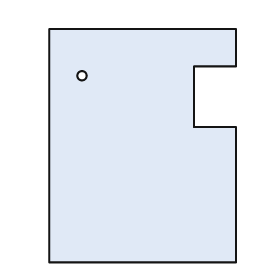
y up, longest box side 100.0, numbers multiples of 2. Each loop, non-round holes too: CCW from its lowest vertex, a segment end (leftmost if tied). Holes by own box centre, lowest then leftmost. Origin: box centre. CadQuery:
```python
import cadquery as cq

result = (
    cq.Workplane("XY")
    .moveTo(-40.0, -50.0)
    .lineTo(40.0, -50.0)
    .lineTo(40.0, 8.0)
    .lineTo(22.0, 8.0)
    .lineTo(22.0, 34.0)
    .lineTo(40.0, 34.0)
    .lineTo(40.0, 50.0)
    .lineTo(-40.0, 50.0)
    .close()
    .moveTo(-26.0, 30.0)
    .circle(2.0)
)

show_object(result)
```